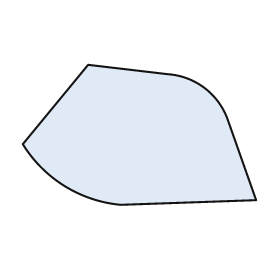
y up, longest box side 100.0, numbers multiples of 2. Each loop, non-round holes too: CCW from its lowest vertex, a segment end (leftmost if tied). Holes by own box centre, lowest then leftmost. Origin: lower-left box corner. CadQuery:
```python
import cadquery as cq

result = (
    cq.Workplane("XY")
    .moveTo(42.0, 0.0)
    .lineTo(100.0, 2.0)
    .lineTo(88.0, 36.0)
    .threePointArc((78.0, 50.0), (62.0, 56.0))
    .lineTo(28.0, 60.0)
    .lineTo(0.0, 26.0)
    .threePointArc((18.0, 8.0), (42.0, 0.0))
    .close()
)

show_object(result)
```